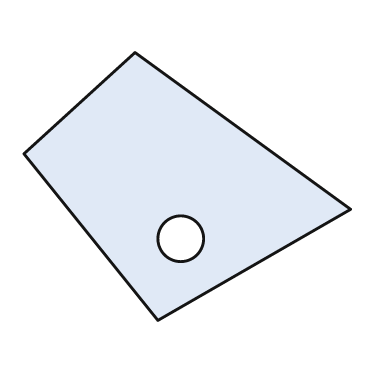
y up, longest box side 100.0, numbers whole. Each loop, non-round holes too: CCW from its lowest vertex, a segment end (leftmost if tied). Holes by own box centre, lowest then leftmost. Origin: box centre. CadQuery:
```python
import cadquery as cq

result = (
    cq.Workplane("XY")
    .moveTo(-9.0, -41.0)
    .lineTo(50.0, -7.0)
    .lineTo(-16.0, 41.0)
    .lineTo(-50.0, 10.0)
    .close()
    .moveTo(-2.0, -16.0)
    .circle(7.0)
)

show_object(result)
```